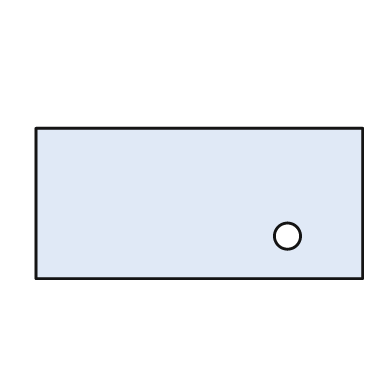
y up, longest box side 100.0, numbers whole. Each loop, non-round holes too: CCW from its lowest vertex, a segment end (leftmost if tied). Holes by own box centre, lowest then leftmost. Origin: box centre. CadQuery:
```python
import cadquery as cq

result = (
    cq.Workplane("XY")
    .moveTo(-50.0, -23.0)
    .lineTo(50.0, -23.0)
    .lineTo(50.0, 23.0)
    .lineTo(-50.0, 23.0)
    .close()
    .moveTo(27.0, -10.0)
    .circle(4.0)
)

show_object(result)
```